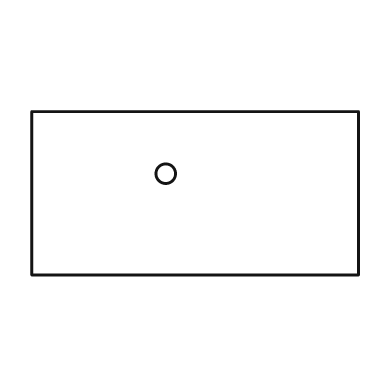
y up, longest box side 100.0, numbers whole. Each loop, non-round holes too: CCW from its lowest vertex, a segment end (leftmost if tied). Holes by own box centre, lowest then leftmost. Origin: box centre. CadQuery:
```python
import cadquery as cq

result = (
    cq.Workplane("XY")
    .moveTo(-50.0, -25.0)
    .lineTo(50.0, -25.0)
    .lineTo(50.0, 25.0)
    .lineTo(-50.0, 25.0)
    .close()
    .moveTo(-9.0, 6.0)
    .circle(3.0)
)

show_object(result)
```